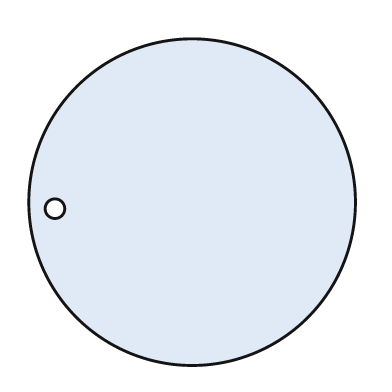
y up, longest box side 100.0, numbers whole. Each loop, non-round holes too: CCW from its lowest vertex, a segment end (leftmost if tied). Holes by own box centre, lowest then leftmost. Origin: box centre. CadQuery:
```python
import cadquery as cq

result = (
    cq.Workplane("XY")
    .moveTo(0.0, 0.0)
    .circle(50.0)
    .moveTo(-42.0, -2.0)
    .circle(3.0)
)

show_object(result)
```